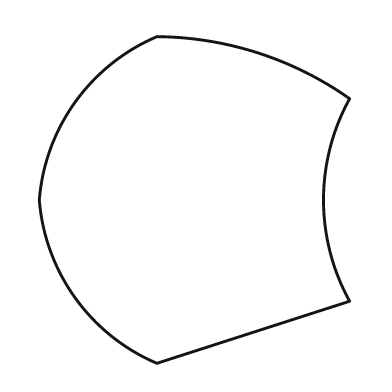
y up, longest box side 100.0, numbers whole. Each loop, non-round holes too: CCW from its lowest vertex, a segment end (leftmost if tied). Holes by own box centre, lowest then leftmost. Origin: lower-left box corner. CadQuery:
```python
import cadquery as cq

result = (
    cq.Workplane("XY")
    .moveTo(36.0, 0.0)
    .lineTo(95.0, 19.0)
    .threePointArc((87.0, 50.0), (95.0, 81.0))
    .threePointArc((67.0, 95.0), (36.0, 100.0))
    .threePointArc((11.0, 80.0), (0.0, 50.0))
    .threePointArc((11.0, 20.0), (36.0, 0.0))
    .close()
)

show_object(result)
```